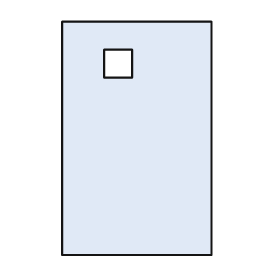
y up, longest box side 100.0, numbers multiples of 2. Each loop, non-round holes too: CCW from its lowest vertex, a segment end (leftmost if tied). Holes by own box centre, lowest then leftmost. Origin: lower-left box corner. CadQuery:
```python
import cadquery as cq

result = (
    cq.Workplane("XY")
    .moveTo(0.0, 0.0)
    .lineTo(64.0, 0.0)
    .lineTo(64.0, 100.0)
    .lineTo(0.0, 100.0)
    .close()
    .moveTo(18.0, 76.0)
    .lineTo(30.0, 76.0)
    .lineTo(30.0, 88.0)
    .lineTo(18.0, 88.0)
    .close()
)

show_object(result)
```